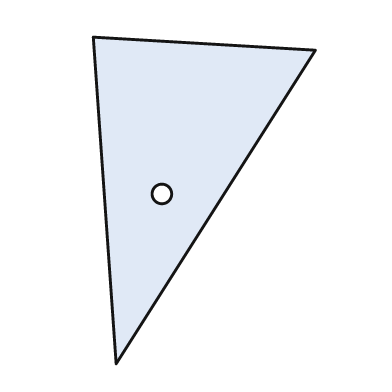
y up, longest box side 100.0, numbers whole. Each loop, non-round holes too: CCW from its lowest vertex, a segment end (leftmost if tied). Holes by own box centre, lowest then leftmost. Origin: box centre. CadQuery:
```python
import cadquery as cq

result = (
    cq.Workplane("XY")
    .moveTo(-27.0, -50.0)
    .lineTo(34.0, 46.0)
    .lineTo(-34.0, 50.0)
    .close()
    .moveTo(-13.0, 2.0)
    .circle(3.0)
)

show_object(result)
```